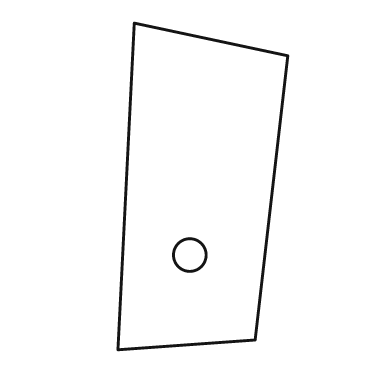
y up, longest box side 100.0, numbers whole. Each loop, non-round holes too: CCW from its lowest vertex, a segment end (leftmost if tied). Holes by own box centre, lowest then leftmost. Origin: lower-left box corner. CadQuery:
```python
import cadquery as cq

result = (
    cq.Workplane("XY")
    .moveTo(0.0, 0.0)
    .lineTo(42.0, 3.0)
    .lineTo(52.0, 90.0)
    .lineTo(5.0, 100.0)
    .close()
    .moveTo(22.0, 29.0)
    .circle(5.0)
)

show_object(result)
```